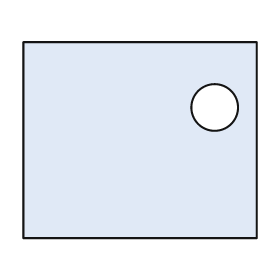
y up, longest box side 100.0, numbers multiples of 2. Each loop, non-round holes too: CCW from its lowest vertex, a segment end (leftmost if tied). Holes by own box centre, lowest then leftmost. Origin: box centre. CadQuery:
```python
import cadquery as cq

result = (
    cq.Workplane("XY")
    .moveTo(-50.0, -42.0)
    .lineTo(50.0, -42.0)
    .lineTo(50.0, 42.0)
    .lineTo(-50.0, 42.0)
    .close()
    .moveTo(32.0, 14.0)
    .circle(10.0)
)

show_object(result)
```